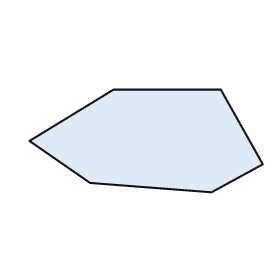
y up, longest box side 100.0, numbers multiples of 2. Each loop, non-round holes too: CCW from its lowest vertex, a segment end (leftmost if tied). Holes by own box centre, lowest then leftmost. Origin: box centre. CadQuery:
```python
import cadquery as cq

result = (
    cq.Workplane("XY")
    .moveTo(28.0, -22.0)
    .lineTo(50.0, -10.0)
    .lineTo(32.0, 22.0)
    .lineTo(-14.0, 22.0)
    .lineTo(-50.0, 0.0)
    .lineTo(-24.0, -18.0)
    .close()
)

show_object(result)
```